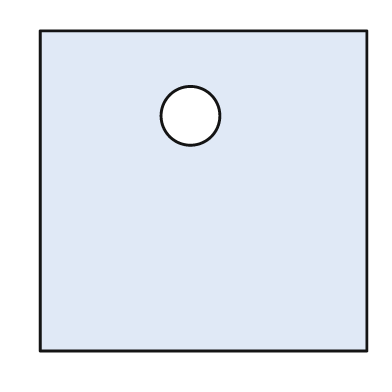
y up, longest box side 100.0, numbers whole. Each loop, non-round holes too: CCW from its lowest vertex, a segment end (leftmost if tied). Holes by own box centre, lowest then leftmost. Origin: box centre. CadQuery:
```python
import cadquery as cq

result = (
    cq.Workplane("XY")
    .moveTo(-50.0, -49.0)
    .lineTo(50.0, -49.0)
    .lineTo(50.0, 49.0)
    .lineTo(-50.0, 49.0)
    .close()
    .moveTo(-4.0, 23.0)
    .circle(9.0)
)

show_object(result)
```